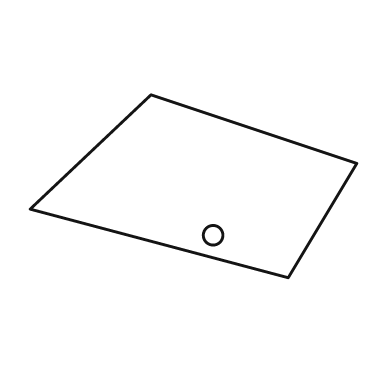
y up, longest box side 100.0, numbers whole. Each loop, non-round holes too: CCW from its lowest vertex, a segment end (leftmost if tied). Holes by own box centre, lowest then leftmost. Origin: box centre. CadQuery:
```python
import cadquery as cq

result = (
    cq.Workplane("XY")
    .moveTo(29.0, -28.0)
    .lineTo(50.0, 7.0)
    .lineTo(-13.0, 28.0)
    .lineTo(-50.0, -7.0)
    .close()
    .moveTo(6.0, -15.0)
    .circle(3.0)
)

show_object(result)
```